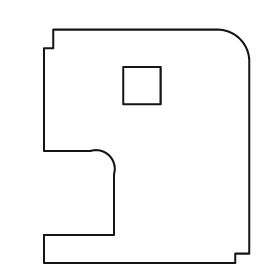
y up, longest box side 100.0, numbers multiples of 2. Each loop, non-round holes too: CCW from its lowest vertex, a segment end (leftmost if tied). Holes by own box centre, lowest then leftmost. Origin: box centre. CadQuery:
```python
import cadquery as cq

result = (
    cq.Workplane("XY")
    .moveTo(-44.0, -50.0)
    .lineTo(38.0, -50.0)
    .lineTo(38.0, -46.0)
    .lineTo(44.0, -46.0)
    .lineTo(44.0, 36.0)
    .threePointArc((40.0, 46.0), (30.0, 50.0))
    .lineTo(-40.0, 50.0)
    .lineTo(-40.0, 42.0)
    .lineTo(-44.0, 42.0)
    .lineTo(-44.0, -2.0)
    .lineTo(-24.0, -2.0)
    .threePointArc((-16.0, -4.0), (-14.0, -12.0))
    .lineTo(-14.0, -38.0)
    .lineTo(-44.0, -38.0)
    .close()
    .moveTo(-10.0, 18.0)
    .lineTo(6.0, 18.0)
    .lineTo(6.0, 34.0)
    .lineTo(-10.0, 34.0)
    .close()
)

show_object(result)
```